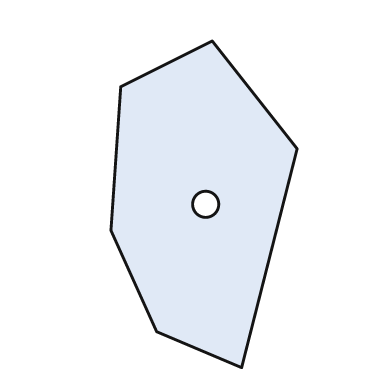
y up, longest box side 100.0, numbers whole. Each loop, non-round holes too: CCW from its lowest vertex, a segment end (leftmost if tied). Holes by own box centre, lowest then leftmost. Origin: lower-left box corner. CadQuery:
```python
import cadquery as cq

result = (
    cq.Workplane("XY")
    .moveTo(40.0, 0.0)
    .lineTo(57.0, 67.0)
    .lineTo(31.0, 100.0)
    .lineTo(3.0, 86.0)
    .lineTo(0.0, 42.0)
    .lineTo(14.0, 11.0)
    .close()
    .moveTo(29.0, 50.0)
    .circle(4.0)
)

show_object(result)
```